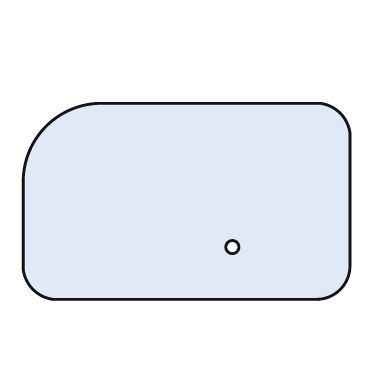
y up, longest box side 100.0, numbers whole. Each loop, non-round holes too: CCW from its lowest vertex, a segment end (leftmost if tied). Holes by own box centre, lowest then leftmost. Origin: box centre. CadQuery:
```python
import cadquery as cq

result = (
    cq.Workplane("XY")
    .moveTo(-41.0, -30.0)
    .lineTo(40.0, -30.0)
    .threePointArc((47.0, -27.0), (50.0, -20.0))
    .lineTo(50.0, 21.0)
    .threePointArc((47.0, 27.0), (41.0, 30.0))
    .lineTo(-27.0, 30.0)
    .threePointArc((-43.0, 23.0), (-50.0, 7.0))
    .lineTo(-50.0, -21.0)
    .threePointArc((-47.0, -27.0), (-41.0, -30.0))
    .close()
    .moveTo(14.0, -14.0)
    .circle(2.0)
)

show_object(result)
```